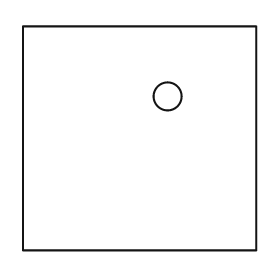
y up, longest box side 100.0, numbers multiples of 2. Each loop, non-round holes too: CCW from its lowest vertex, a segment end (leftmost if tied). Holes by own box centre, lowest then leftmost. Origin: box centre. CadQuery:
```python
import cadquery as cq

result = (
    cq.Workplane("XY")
    .moveTo(-50.0, -48.0)
    .lineTo(50.0, -48.0)
    .lineTo(50.0, 48.0)
    .lineTo(-50.0, 48.0)
    .close()
    .moveTo(12.0, 18.0)
    .circle(6.0)
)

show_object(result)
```